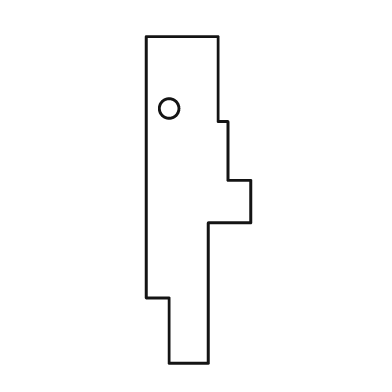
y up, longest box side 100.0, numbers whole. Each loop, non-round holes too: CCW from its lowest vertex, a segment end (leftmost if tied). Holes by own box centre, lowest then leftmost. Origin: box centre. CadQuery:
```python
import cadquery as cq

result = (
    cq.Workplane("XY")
    .moveTo(-9.0, -50.0)
    .lineTo(3.0, -50.0)
    .lineTo(3.0, -7.0)
    .lineTo(16.0, -7.0)
    .lineTo(16.0, 6.0)
    .lineTo(9.0, 6.0)
    .lineTo(9.0, 24.0)
    .lineTo(6.0, 24.0)
    .lineTo(6.0, 50.0)
    .lineTo(-16.0, 50.0)
    .lineTo(-16.0, -30.0)
    .lineTo(-9.0, -30.0)
    .close()
    .moveTo(-9.0, 28.0)
    .circle(3.0)
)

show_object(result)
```